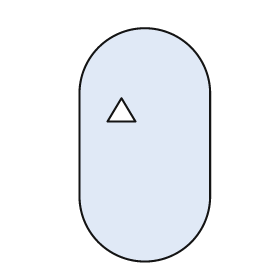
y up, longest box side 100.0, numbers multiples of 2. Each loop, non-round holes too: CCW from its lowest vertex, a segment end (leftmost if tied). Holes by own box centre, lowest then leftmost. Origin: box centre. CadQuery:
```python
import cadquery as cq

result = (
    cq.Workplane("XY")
    .moveTo(-28.0, -22.0)
    .threePointArc((0.0, -50.0), (28.0, -22.0))
    .lineTo(28.0, 22.0)
    .threePointArc((0.0, 50.0), (-28.0, 22.0))
    .close()
    .moveTo(-16.0, 10.0)
    .lineTo(-4.0, 10.0)
    .lineTo(-10.0, 20.0)
    .close()
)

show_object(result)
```